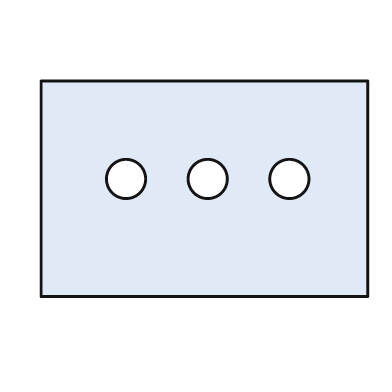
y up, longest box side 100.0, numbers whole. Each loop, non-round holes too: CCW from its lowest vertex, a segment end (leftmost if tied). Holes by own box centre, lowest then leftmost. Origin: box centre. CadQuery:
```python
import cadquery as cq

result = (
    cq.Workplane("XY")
    .moveTo(-50.0, -33.0)
    .lineTo(50.0, -33.0)
    .lineTo(50.0, 33.0)
    .lineTo(-50.0, 33.0)
    .close()
    .moveTo(-24.0, 3.0)
    .circle(6.0)
    .moveTo(1.0, 3.0)
    .circle(6.0)
    .moveTo(26.0, 3.0)
    .circle(6.0)
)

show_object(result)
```